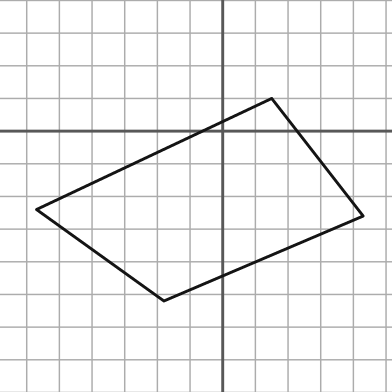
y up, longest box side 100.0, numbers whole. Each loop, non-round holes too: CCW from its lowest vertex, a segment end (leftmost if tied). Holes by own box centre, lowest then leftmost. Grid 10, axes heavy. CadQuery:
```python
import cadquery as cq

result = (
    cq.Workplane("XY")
    .moveTo(-18.0, -52.0)
    .lineTo(43.0, -26.0)
    .lineTo(15.0, 10.0)
    .lineTo(-57.0, -24.0)
    .close()
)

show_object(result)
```